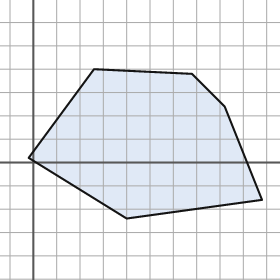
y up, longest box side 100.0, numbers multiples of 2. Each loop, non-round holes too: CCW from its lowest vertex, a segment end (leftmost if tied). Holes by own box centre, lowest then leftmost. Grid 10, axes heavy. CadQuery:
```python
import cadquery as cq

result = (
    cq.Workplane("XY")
    .moveTo(40.0, -24.0)
    .lineTo(98.0, -16.0)
    .lineTo(82.0, 24.0)
    .lineTo(68.0, 38.0)
    .lineTo(26.0, 40.0)
    .lineTo(-2.0, 2.0)
    .close()
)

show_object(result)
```